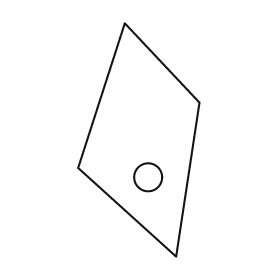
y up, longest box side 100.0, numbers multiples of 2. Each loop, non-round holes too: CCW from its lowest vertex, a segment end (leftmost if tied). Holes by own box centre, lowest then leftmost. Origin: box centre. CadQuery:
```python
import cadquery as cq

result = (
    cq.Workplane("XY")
    .moveTo(16.0, -50.0)
    .lineTo(26.0, 16.0)
    .lineTo(-6.0, 50.0)
    .lineTo(-26.0, -12.0)
    .close()
    .moveTo(4.0, -16.0)
    .circle(6.0)
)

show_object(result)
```